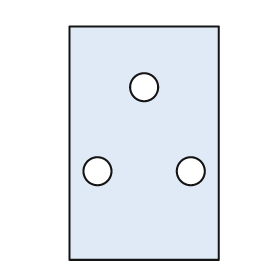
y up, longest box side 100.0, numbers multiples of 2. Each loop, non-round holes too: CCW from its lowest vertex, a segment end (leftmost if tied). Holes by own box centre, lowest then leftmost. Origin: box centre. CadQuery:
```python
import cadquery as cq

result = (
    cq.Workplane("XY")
    .moveTo(-32.0, -50.0)
    .lineTo(32.0, -50.0)
    .lineTo(32.0, 50.0)
    .lineTo(-32.0, 50.0)
    .close()
    .moveTo(-20.0, -12.0)
    .circle(6.0)
    .moveTo(20.0, -12.0)
    .circle(6.0)
    .moveTo(0.0, 24.0)
    .circle(6.0)
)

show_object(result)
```